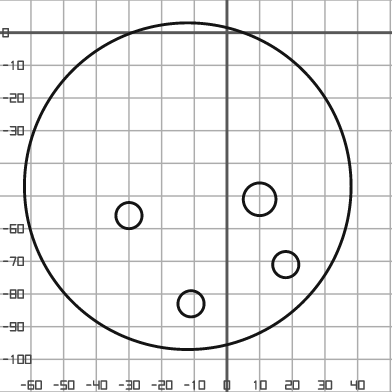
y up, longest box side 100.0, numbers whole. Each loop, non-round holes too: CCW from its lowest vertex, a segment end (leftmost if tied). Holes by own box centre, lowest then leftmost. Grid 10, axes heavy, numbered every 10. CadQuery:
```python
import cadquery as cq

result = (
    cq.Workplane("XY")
    .moveTo(-12.0, -47.0)
    .circle(50.0)
    .moveTo(-11.0, -83.0)
    .circle(4.0)
    .moveTo(18.0, -71.0)
    .circle(4.0)
    .moveTo(-30.0, -56.0)
    .circle(4.0)
    .moveTo(10.0, -51.0)
    .circle(5.0)
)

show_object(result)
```